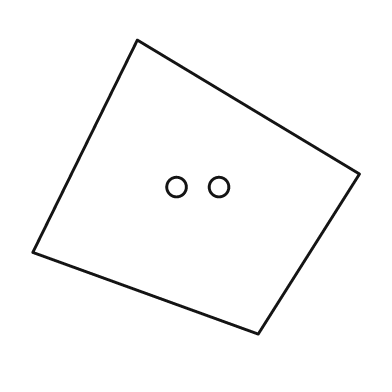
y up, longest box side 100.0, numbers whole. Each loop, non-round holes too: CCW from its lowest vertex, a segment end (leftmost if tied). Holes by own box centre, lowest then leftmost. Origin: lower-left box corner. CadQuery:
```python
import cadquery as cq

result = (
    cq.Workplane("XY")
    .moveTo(69.0, 0.0)
    .lineTo(100.0, 49.0)
    .lineTo(32.0, 90.0)
    .lineTo(0.0, 25.0)
    .close()
    .moveTo(44.0, 45.0)
    .circle(3.0)
    .moveTo(57.0, 45.0)
    .circle(3.0)
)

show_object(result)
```